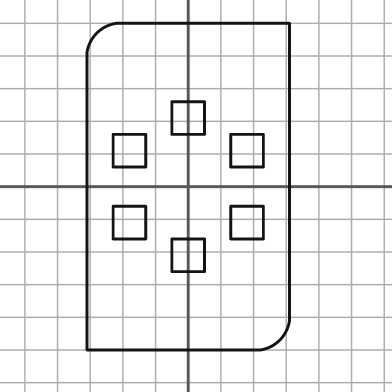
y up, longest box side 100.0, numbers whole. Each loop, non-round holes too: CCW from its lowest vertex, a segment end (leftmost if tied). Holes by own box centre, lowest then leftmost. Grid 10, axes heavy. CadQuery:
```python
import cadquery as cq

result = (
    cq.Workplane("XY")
    .moveTo(-31.0, -50.0)
    .lineTo(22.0, -50.0)
    .threePointArc((28.0, -47.0), (31.0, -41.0))
    .lineTo(31.0, 50.0)
    .lineTo(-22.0, 50.0)
    .threePointArc((-28.0, 47.0), (-31.0, 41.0))
    .close()
    .moveTo(-5.0, -26.0)
    .lineTo(5.0, -26.0)
    .lineTo(5.0, -16.0)
    .lineTo(-5.0, -16.0)
    .close()
    .moveTo(-23.0, -16.0)
    .lineTo(-13.0, -16.0)
    .lineTo(-13.0, -6.0)
    .lineTo(-23.0, -6.0)
    .close()
    .moveTo(13.0, -16.0)
    .lineTo(23.0, -16.0)
    .lineTo(23.0, -6.0)
    .lineTo(13.0, -6.0)
    .close()
    .moveTo(-23.0, 6.0)
    .lineTo(-13.0, 6.0)
    .lineTo(-13.0, 16.0)
    .lineTo(-23.0, 16.0)
    .close()
    .moveTo(13.0, 6.0)
    .lineTo(23.0, 6.0)
    .lineTo(23.0, 16.0)
    .lineTo(13.0, 16.0)
    .close()
    .moveTo(-5.0, 16.0)
    .lineTo(5.0, 16.0)
    .lineTo(5.0, 26.0)
    .lineTo(-5.0, 26.0)
    .close()
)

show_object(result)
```